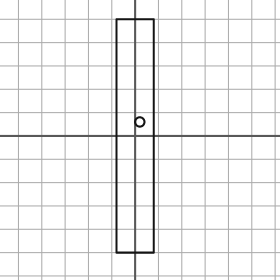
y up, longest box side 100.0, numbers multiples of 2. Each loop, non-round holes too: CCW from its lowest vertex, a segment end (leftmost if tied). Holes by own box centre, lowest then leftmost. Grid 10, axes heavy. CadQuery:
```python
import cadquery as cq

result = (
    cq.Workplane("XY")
    .moveTo(-8.0, -50.0)
    .lineTo(8.0, -50.0)
    .lineTo(8.0, 50.0)
    .lineTo(-8.0, 50.0)
    .close()
    .moveTo(2.0, 6.0)
    .circle(2.0)
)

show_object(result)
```